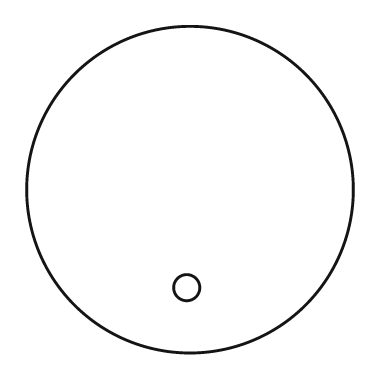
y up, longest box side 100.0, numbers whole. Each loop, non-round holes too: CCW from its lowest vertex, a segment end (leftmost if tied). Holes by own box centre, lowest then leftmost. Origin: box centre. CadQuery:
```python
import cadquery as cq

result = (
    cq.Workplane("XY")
    .moveTo(0.0, 0.0)
    .circle(50.0)
    .moveTo(-1.0, -30.0)
    .circle(4.0)
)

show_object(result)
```